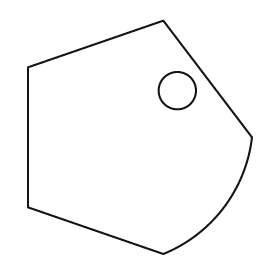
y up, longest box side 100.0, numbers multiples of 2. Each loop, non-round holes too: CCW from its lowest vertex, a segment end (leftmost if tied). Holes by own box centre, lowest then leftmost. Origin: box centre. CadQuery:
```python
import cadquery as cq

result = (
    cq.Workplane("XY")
    .moveTo(10.0, -50.0)
    .threePointArc((36.0, -30.0), (48.0, 0.0))
    .lineTo(10.0, 50.0)
    .lineTo(-48.0, 30.0)
    .lineTo(-48.0, -30.0)
    .close()
    .moveTo(16.0, 20.0)
    .circle(8.0)
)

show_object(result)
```